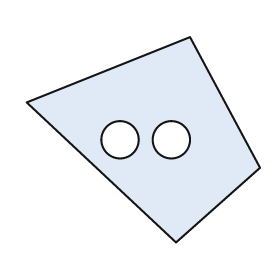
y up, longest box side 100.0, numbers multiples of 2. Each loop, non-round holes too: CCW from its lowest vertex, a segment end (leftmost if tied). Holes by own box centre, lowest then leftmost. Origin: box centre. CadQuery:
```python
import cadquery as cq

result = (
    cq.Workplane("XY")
    .moveTo(14.0, -44.0)
    .lineTo(50.0, -12.0)
    .lineTo(20.0, 44.0)
    .lineTo(-50.0, 16.0)
    .close()
    .moveTo(-10.0, 0.0)
    .circle(8.0)
    .moveTo(12.0, 0.0)
    .circle(8.0)
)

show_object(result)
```